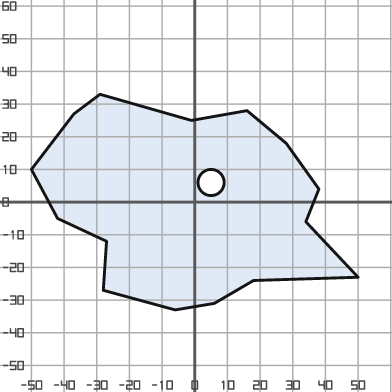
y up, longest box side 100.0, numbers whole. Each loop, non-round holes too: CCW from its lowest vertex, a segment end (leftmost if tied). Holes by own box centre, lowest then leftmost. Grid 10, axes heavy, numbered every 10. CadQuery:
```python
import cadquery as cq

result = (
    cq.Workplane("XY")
    .moveTo(-6.0, -33.0)
    .lineTo(6.0, -31.0)
    .lineTo(18.0, -24.0)
    .lineTo(50.0, -23.0)
    .lineTo(34.0, -6.0)
    .lineTo(38.0, 4.0)
    .lineTo(28.0, 18.0)
    .lineTo(16.0, 28.0)
    .lineTo(-1.0, 25.0)
    .lineTo(-29.0, 33.0)
    .lineTo(-37.0, 27.0)
    .lineTo(-50.0, 10.0)
    .lineTo(-42.0, -5.0)
    .lineTo(-27.0, -12.0)
    .lineTo(-28.0, -27.0)
    .close()
    .moveTo(5.0, 6.0)
    .circle(4.0)
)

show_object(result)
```